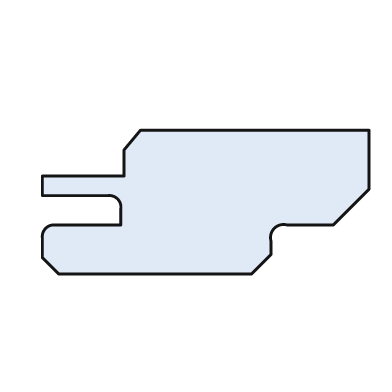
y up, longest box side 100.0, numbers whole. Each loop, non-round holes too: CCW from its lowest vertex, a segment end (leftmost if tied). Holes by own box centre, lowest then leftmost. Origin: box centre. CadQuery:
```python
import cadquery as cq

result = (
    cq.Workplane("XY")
    .moveTo(-45.0, -22.0)
    .lineTo(14.0, -22.0)
    .lineTo(20.0, -16.0)
    .lineTo(20.0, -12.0)
    .threePointArc((21.0, -8.0), (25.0, -7.0))
    .lineTo(39.0, -7.0)
    .lineTo(50.0, 4.0)
    .lineTo(50.0, 22.0)
    .lineTo(-20.0, 22.0)
    .lineTo(-25.0, 16.0)
    .lineTo(-25.0, 8.0)
    .lineTo(-50.0, 8.0)
    .lineTo(-50.0, 2.0)
    .lineTo(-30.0, 2.0)
    .threePointArc((-27.0, 1.0), (-26.0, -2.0))
    .lineTo(-26.0, -7.0)
    .lineTo(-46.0, -7.0)
    .threePointArc((-49.0, -8.0), (-50.0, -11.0))
    .lineTo(-50.0, -17.0)
    .close()
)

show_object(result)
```